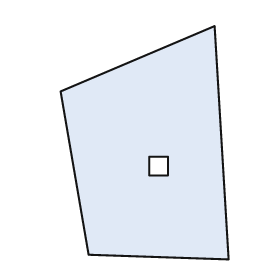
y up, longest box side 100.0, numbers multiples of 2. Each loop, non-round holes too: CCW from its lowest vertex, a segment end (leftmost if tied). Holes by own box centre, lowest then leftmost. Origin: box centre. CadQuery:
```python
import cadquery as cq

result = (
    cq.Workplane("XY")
    .moveTo(36.0, -50.0)
    .lineTo(30.0, 50.0)
    .lineTo(-36.0, 22.0)
    .lineTo(-24.0, -48.0)
    .close()
    .moveTo(2.0, -14.0)
    .lineTo(10.0, -14.0)
    .lineTo(10.0, -6.0)
    .lineTo(2.0, -6.0)
    .close()
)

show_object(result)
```